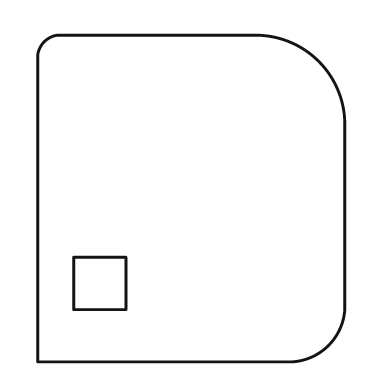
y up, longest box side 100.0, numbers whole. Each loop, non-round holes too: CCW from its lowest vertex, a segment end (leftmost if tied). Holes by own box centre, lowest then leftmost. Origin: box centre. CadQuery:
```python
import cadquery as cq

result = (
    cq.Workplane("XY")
    .moveTo(-47.0, -50.0)
    .lineTo(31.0, -50.0)
    .threePointArc((42.0, -45.0), (47.0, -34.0))
    .lineTo(47.0, 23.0)
    .threePointArc((39.0, 42.0), (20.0, 50.0))
    .lineTo(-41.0, 50.0)
    .threePointArc((-45.0, 48.0), (-47.0, 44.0))
    .close()
    .moveTo(-36.0, -34.0)
    .lineTo(-20.0, -34.0)
    .lineTo(-20.0, -18.0)
    .lineTo(-36.0, -18.0)
    .close()
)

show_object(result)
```